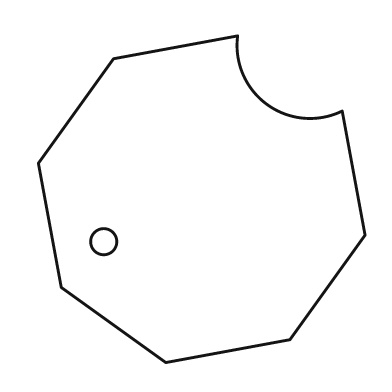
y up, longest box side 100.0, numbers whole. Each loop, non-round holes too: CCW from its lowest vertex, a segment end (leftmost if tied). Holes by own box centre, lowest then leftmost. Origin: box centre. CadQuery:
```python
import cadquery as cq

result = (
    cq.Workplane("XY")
    .moveTo(-11.0, -50.0)
    .lineTo(27.0, -43.0)
    .lineTo(50.0, -11.0)
    .lineTo(43.0, 27.0)
    .threePointArc((20.0, 29.0), (11.0, 50.0))
    .lineTo(-27.0, 43.0)
    .lineTo(-50.0, 11.0)
    .lineTo(-43.0, -27.0)
    .close()
    .moveTo(-30.0, -13.0)
    .circle(4.0)
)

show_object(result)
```